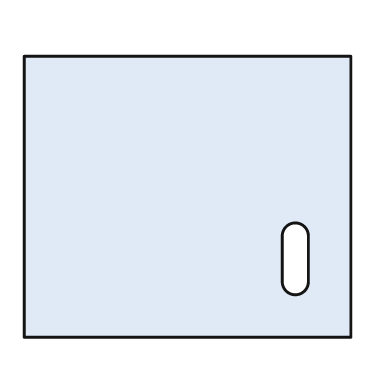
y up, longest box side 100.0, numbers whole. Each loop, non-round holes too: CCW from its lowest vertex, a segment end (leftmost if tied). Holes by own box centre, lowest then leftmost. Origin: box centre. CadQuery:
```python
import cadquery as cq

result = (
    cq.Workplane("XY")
    .moveTo(-50.0, -43.0)
    .lineTo(50.0, -43.0)
    .lineTo(50.0, 43.0)
    .lineTo(-50.0, 43.0)
    .close()
    .moveTo(29.0, -26.0)
    .threePointArc((33.0, -30.0), (37.0, -26.0))
    .lineTo(37.0, -12.0)
    .threePointArc((33.0, -8.0), (29.0, -12.0))
    .close()
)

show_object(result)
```